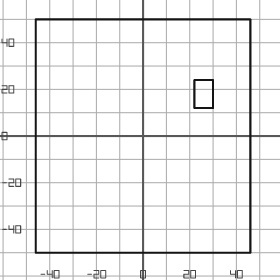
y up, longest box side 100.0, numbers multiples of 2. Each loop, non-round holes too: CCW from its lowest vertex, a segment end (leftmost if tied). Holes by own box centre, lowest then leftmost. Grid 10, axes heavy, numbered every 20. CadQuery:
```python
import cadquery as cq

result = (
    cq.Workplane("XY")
    .moveTo(-46.0, -50.0)
    .lineTo(46.0, -50.0)
    .lineTo(46.0, 50.0)
    .lineTo(-46.0, 50.0)
    .close()
    .moveTo(22.0, 12.0)
    .lineTo(30.0, 12.0)
    .lineTo(30.0, 24.0)
    .lineTo(22.0, 24.0)
    .close()
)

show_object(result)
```